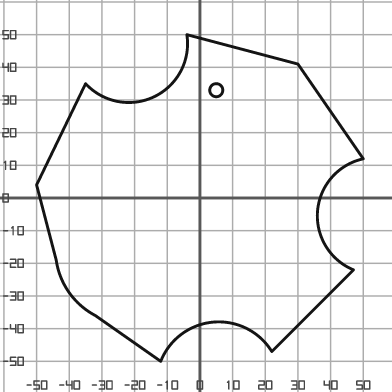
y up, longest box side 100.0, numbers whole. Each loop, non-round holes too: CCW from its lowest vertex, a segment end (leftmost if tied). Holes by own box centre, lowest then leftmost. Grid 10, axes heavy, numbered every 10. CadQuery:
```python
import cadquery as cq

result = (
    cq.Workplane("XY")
    .moveTo(-12.0, -50.0)
    .threePointArc((4.0, -38.0), (22.0, -47.0))
    .lineTo(47.0, -22.0)
    .threePointArc((36.0, -4.0), (50.0, 12.0))
    .lineTo(30.0, 41.0)
    .lineTo(-4.0, 50.0)
    .threePointArc((-14.0, 31.0), (-35.0, 35.0))
    .lineTo(-50.0, 4.0)
    .lineTo(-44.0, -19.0)
    .threePointArc((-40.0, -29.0), (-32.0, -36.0))
    .close()
    .moveTo(5.0, 33.0)
    .circle(2.0)
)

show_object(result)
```